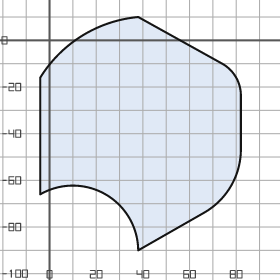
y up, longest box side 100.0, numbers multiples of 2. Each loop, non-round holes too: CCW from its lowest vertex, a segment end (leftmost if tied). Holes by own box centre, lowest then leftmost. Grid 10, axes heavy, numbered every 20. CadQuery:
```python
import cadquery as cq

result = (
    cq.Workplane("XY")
    .moveTo(38.0, -90.0)
    .lineTo(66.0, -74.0)
    .threePointArc((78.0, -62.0), (82.0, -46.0))
    .lineTo(82.0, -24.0)
    .threePointArc((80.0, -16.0), (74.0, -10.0))
    .lineTo(38.0, 10.0)
    .threePointArc((14.0, 2.0), (-4.0, -16.0))
    .lineTo(-4.0, -66.0)
    .threePointArc((24.0, -66.0), (38.0, -90.0))
    .close()
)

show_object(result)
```